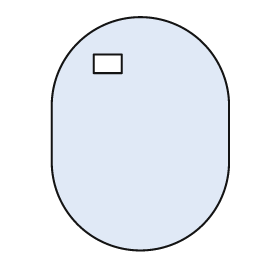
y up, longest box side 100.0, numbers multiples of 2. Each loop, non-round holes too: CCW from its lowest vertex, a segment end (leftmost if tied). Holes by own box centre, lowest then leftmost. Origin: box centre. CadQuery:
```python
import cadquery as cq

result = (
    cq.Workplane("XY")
    .moveTo(-38.0, -12.0)
    .threePointArc((0.0, -50.0), (38.0, -12.0))
    .lineTo(38.0, 12.0)
    .threePointArc((0.0, 50.0), (-38.0, 12.0))
    .close()
    .moveTo(-20.0, 26.0)
    .lineTo(-8.0, 26.0)
    .lineTo(-8.0, 34.0)
    .lineTo(-20.0, 34.0)
    .close()
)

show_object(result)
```